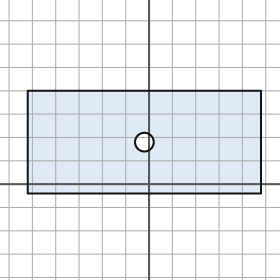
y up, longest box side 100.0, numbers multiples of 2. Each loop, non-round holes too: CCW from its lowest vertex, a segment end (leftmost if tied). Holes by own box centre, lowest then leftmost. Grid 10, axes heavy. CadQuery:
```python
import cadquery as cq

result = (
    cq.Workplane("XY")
    .moveTo(-52.0, -4.0)
    .lineTo(48.0, -4.0)
    .lineTo(48.0, 40.0)
    .lineTo(-52.0, 40.0)
    .close()
    .moveTo(-2.0, 18.0)
    .circle(4.0)
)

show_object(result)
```